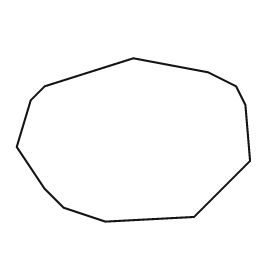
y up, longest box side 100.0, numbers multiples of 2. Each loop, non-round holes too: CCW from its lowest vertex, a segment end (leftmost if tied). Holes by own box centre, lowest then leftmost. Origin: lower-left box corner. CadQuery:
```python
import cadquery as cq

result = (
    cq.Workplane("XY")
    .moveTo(38.0, 0.0)
    .lineTo(76.0, 2.0)
    .lineTo(100.0, 26.0)
    .lineTo(98.0, 50.0)
    .lineTo(94.0, 58.0)
    .lineTo(82.0, 64.0)
    .lineTo(50.0, 70.0)
    .lineTo(12.0, 58.0)
    .lineTo(6.0, 52.0)
    .lineTo(0.0, 32.0)
    .lineTo(12.0, 14.0)
    .lineTo(20.0, 6.0)
    .close()
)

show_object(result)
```